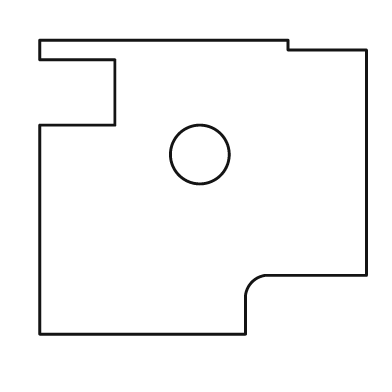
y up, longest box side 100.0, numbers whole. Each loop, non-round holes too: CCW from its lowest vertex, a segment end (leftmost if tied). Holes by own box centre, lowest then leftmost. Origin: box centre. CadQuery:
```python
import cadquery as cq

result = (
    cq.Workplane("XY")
    .moveTo(-50.0, -45.0)
    .lineTo(13.0, -45.0)
    .lineTo(13.0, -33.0)
    .threePointArc((15.0, -29.0), (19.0, -27.0))
    .lineTo(50.0, -27.0)
    .lineTo(50.0, 42.0)
    .lineTo(26.0, 42.0)
    .lineTo(26.0, 45.0)
    .lineTo(-50.0, 45.0)
    .lineTo(-50.0, 39.0)
    .lineTo(-27.0, 39.0)
    .lineTo(-27.0, 19.0)
    .lineTo(-50.0, 19.0)
    .close()
    .moveTo(-1.0, 10.0)
    .circle(9.0)
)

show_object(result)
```